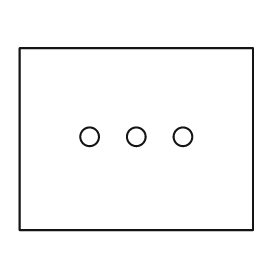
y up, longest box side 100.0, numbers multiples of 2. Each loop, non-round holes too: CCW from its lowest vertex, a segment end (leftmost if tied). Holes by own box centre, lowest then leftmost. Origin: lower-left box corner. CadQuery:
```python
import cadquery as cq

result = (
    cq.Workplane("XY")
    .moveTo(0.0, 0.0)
    .lineTo(100.0, 0.0)
    .lineTo(100.0, 78.0)
    .lineTo(0.0, 78.0)
    .close()
    .moveTo(30.0, 40.0)
    .circle(4.0)
    .moveTo(50.0, 40.0)
    .circle(4.0)
    .moveTo(70.0, 40.0)
    .circle(4.0)
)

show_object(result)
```